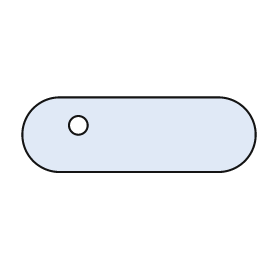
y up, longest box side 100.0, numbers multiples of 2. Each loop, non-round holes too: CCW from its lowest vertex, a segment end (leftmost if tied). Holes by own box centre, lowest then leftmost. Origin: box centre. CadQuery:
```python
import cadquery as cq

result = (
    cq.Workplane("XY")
    .moveTo(-34.0, -16.0)
    .lineTo(34.0, -16.0)
    .threePointArc((50.0, 0.0), (34.0, 16.0))
    .lineTo(-34.0, 16.0)
    .threePointArc((-50.0, 0.0), (-34.0, -16.0))
    .close()
    .moveTo(-26.0, 4.0)
    .circle(4.0)
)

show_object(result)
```